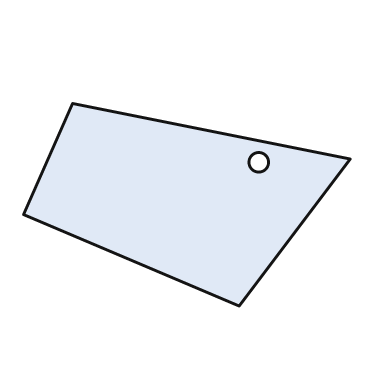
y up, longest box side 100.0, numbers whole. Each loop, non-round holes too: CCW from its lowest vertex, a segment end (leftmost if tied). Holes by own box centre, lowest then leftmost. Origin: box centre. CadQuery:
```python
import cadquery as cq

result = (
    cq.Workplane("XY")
    .moveTo(16.0, -31.0)
    .lineTo(50.0, 14.0)
    .lineTo(-35.0, 31.0)
    .lineTo(-50.0, -3.0)
    .close()
    .moveTo(22.0, 13.0)
    .circle(3.0)
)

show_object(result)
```